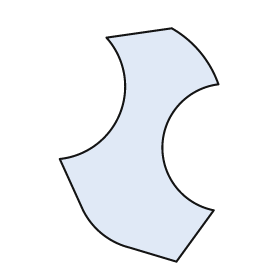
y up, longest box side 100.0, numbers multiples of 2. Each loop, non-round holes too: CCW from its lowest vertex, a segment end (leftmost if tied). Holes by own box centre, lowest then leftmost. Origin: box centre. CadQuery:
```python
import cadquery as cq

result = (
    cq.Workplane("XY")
    .moveTo(16.0, -50.0)
    .lineTo(32.0, -28.0)
    .threePointArc((10.0, 0.0), (34.0, 26.0))
    .threePointArc((26.0, 40.0), (14.0, 50.0))
    .lineTo(-14.0, 46.0)
    .threePointArc((-8.0, 14.0), (-34.0, -6.0))
    .lineTo(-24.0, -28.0)
    .threePointArc((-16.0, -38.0), (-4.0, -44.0))
    .close()
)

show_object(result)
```